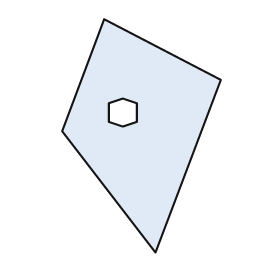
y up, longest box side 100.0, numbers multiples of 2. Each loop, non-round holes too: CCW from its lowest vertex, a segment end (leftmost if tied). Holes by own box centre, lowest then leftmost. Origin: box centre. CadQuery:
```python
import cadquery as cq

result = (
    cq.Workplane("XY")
    .moveTo(6.0, -50.0)
    .lineTo(34.0, 24.0)
    .lineTo(-16.0, 50.0)
    .lineTo(-34.0, 2.0)
    .close()
    .moveTo(-8.0, 4.0)
    .lineTo(-2.0, 6.0)
    .lineTo(-2.0, 14.0)
    .lineTo(-8.0, 16.0)
    .lineTo(-14.0, 14.0)
    .lineTo(-14.0, 6.0)
    .close()
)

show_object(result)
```